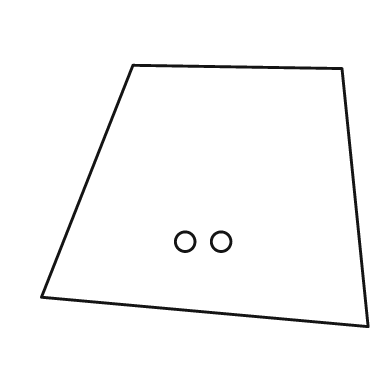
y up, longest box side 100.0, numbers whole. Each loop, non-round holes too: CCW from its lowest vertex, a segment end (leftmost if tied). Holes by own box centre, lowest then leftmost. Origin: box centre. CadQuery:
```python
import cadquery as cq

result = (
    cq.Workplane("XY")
    .moveTo(50.0, -40.0)
    .lineTo(42.0, 39.0)
    .lineTo(-22.0, 40.0)
    .lineTo(-50.0, -31.0)
    .close()
    .moveTo(-6.0, -14.0)
    .circle(3.0)
    .moveTo(5.0, -14.0)
    .circle(3.0)
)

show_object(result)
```